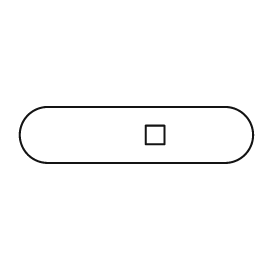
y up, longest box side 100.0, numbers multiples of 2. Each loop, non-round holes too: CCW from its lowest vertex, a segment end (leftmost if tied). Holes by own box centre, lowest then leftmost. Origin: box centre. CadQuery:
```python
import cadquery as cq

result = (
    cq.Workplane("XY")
    .moveTo(-38.0, -12.0)
    .lineTo(38.0, -12.0)
    .threePointArc((50.0, 0.0), (38.0, 12.0))
    .lineTo(-38.0, 12.0)
    .threePointArc((-50.0, 0.0), (-38.0, -12.0))
    .close()
    .moveTo(4.0, -4.0)
    .lineTo(12.0, -4.0)
    .lineTo(12.0, 4.0)
    .lineTo(4.0, 4.0)
    .close()
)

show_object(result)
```